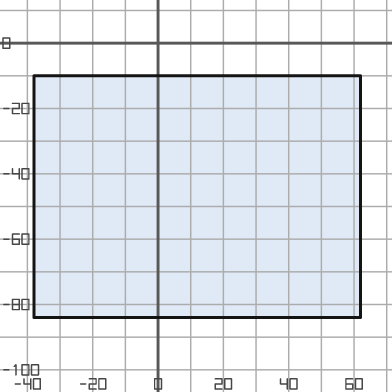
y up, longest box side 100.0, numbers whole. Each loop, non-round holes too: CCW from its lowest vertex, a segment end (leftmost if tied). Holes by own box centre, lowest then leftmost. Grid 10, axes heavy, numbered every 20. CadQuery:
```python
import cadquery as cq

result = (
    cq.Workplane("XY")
    .moveTo(-38.0, -84.0)
    .lineTo(62.0, -84.0)
    .lineTo(62.0, -10.0)
    .lineTo(-38.0, -10.0)
    .close()
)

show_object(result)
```